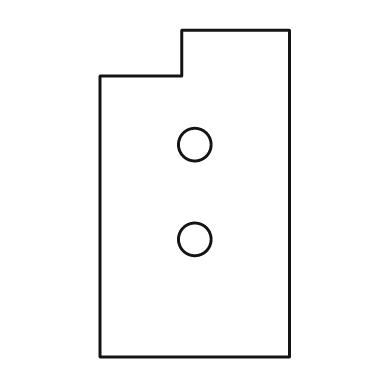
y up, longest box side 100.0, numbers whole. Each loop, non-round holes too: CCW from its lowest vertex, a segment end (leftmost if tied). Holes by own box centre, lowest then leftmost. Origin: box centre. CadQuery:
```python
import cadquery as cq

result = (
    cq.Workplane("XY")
    .moveTo(-29.0, -50.0)
    .lineTo(29.0, -50.0)
    .lineTo(29.0, 50.0)
    .lineTo(-4.0, 50.0)
    .lineTo(-4.0, 36.0)
    .lineTo(-29.0, 36.0)
    .close()
    .moveTo(0.0, -14.0)
    .circle(5.0)
    .moveTo(0.0, 15.0)
    .circle(5.0)
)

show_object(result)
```